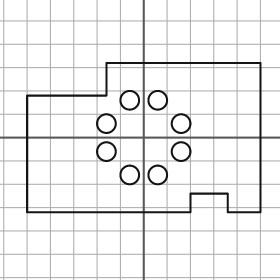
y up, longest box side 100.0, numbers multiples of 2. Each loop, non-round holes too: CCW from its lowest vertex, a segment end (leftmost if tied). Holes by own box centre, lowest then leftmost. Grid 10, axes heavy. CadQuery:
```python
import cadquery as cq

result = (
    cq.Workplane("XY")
    .moveTo(-50.0, -32.0)
    .lineTo(20.0, -32.0)
    .lineTo(20.0, -24.0)
    .lineTo(36.0, -24.0)
    .lineTo(36.0, -32.0)
    .lineTo(50.0, -32.0)
    .lineTo(50.0, 32.0)
    .lineTo(-16.0, 32.0)
    .lineTo(-16.0, 18.0)
    .lineTo(-50.0, 18.0)
    .close()
    .moveTo(-6.0, -16.0)
    .circle(4.0)
    .moveTo(6.0, -16.0)
    .circle(4.0)
    .moveTo(-16.0, -6.0)
    .circle(4.0)
    .moveTo(16.0, -6.0)
    .circle(4.0)
    .moveTo(-16.0, 6.0)
    .circle(4.0)
    .moveTo(16.0, 6.0)
    .circle(4.0)
    .moveTo(-6.0, 16.0)
    .circle(4.0)
    .moveTo(6.0, 16.0)
    .circle(4.0)
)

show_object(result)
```